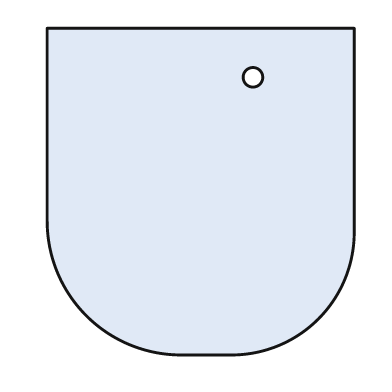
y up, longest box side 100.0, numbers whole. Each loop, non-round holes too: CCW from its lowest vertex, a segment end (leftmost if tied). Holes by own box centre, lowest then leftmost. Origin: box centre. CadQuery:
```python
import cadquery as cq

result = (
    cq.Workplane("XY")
    .moveTo(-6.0, -50.0)
    .lineTo(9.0, -50.0)
    .threePointArc((36.0, -39.0), (47.0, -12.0))
    .lineTo(47.0, 50.0)
    .lineTo(-47.0, 50.0)
    .lineTo(-47.0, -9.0)
    .threePointArc((-35.0, -38.0), (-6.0, -50.0))
    .close()
    .moveTo(16.0, 35.0)
    .circle(3.0)
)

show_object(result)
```